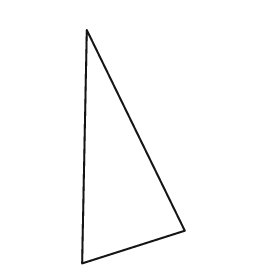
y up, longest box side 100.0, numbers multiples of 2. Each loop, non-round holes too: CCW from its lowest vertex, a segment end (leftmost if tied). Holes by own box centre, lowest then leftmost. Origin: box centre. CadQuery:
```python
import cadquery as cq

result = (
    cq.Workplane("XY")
    .moveTo(-22.0, -50.0)
    .lineTo(22.0, -36.0)
    .lineTo(-20.0, 50.0)
    .close()
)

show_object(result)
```